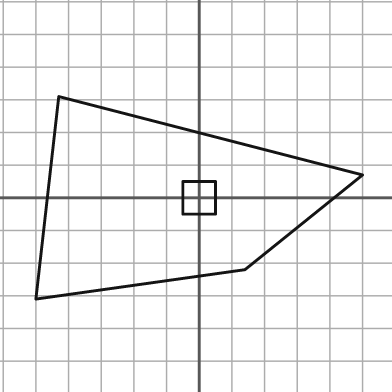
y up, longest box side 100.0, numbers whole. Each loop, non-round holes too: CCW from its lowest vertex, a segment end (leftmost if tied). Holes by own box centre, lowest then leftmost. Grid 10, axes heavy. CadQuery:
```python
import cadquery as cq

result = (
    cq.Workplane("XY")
    .moveTo(-50.0, -31.0)
    .lineTo(14.0, -22.0)
    .lineTo(50.0, 7.0)
    .lineTo(-43.0, 31.0)
    .close()
    .moveTo(-5.0, -5.0)
    .lineTo(5.0, -5.0)
    .lineTo(5.0, 5.0)
    .lineTo(-5.0, 5.0)
    .close()
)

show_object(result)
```